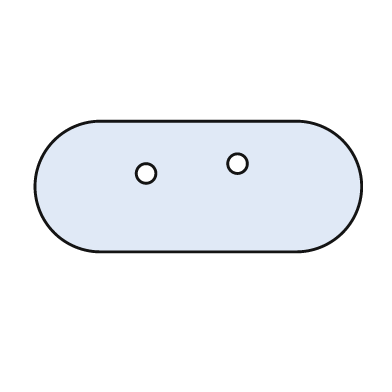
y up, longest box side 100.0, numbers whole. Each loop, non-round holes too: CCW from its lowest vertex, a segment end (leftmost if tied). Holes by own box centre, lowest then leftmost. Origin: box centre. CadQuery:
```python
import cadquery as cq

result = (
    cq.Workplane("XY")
    .moveTo(-30.0, -20.0)
    .lineTo(30.0, -20.0)
    .threePointArc((50.0, 0.0), (30.0, 20.0))
    .lineTo(-30.0, 20.0)
    .threePointArc((-50.0, 0.0), (-30.0, -20.0))
    .close()
    .moveTo(-16.0, 4.0)
    .circle(3.0)
    .moveTo(12.0, 7.0)
    .circle(3.0)
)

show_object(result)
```